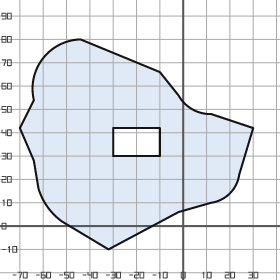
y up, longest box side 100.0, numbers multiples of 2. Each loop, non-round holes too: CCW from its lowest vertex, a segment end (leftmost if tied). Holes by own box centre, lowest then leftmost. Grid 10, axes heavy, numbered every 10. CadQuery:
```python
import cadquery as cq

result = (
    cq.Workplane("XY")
    .moveTo(-32.0, -10.0)
    .lineTo(-2.0, 6.0)
    .lineTo(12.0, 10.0)
    .threePointArc((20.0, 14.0), (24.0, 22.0))
    .lineTo(30.0, 42.0)
    .lineTo(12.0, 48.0)
    .threePointArc((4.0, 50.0), (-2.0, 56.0))
    .lineTo(-10.0, 66.0)
    .lineTo(-44.0, 80.0)
    .threePointArc((-60.0, 72.0), (-64.0, 54.0))
    .lineTo(-70.0, 42.0)
    .lineTo(-64.0, 28.0)
    .lineTo(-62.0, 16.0)
    .threePointArc((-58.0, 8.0), (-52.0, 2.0))
    .close()
    .moveTo(-30.0, 30.0)
    .lineTo(-10.0, 30.0)
    .lineTo(-10.0, 42.0)
    .lineTo(-30.0, 42.0)
    .close()
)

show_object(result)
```